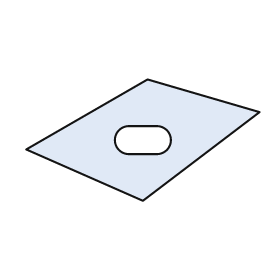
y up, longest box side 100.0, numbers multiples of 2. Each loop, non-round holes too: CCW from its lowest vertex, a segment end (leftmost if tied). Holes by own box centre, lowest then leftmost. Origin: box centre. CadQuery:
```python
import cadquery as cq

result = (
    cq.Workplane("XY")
    .moveTo(0.0, -26.0)
    .lineTo(50.0, 12.0)
    .lineTo(2.0, 26.0)
    .lineTo(-50.0, -4.0)
    .close()
    .moveTo(-6.0, -6.0)
    .lineTo(6.0, -6.0)
    .threePointArc((12.0, 0.0), (6.0, 6.0))
    .lineTo(-6.0, 6.0)
    .threePointArc((-12.0, 0.0), (-6.0, -6.0))
    .close()
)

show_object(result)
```